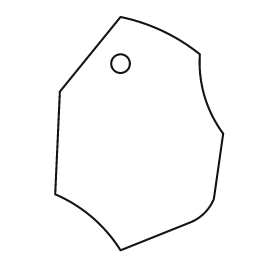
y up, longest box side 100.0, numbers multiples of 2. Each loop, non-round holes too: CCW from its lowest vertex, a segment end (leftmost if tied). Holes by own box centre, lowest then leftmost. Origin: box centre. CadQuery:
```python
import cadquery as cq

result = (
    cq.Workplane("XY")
    .moveTo(-8.0, -50.0)
    .lineTo(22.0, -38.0)
    .threePointArc((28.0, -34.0), (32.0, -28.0))
    .lineTo(36.0, 0.0)
    .threePointArc((28.0, 16.0), (26.0, 34.0))
    .threePointArc((10.0, 44.0), (-8.0, 50.0))
    .lineTo(-34.0, 18.0)
    .lineTo(-36.0, -26.0)
    .threePointArc((-20.0, -36.0), (-8.0, -50.0))
    .close()
    .moveTo(-8.0, 30.0)
    .circle(4.0)
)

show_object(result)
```